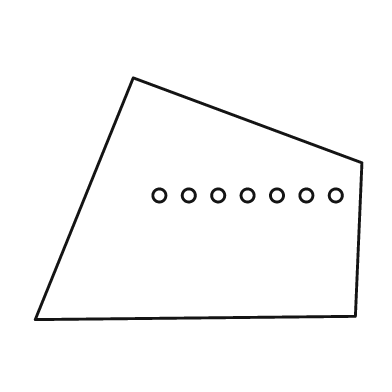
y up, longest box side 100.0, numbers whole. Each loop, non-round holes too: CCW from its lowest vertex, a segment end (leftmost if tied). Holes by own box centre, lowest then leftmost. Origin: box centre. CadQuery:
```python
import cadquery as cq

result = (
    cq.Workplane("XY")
    .moveTo(-50.0, -37.0)
    .lineTo(48.0, -36.0)
    .lineTo(50.0, 11.0)
    .lineTo(-20.0, 37.0)
    .close()
    .moveTo(-12.0, 1.0)
    .circle(2.0)
    .moveTo(-3.0, 1.0)
    .circle(2.0)
    .moveTo(6.0, 1.0)
    .circle(2.0)
    .moveTo(15.0, 1.0)
    .circle(2.0)
    .moveTo(24.0, 1.0)
    .circle(2.0)
    .moveTo(33.0, 1.0)
    .circle(2.0)
    .moveTo(42.0, 1.0)
    .circle(2.0)
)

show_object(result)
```